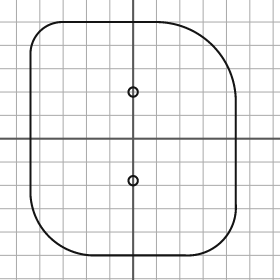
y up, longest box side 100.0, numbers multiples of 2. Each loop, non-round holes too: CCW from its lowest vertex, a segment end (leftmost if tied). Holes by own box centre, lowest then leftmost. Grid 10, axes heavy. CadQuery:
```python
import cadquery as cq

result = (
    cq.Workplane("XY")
    .moveTo(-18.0, -50.0)
    .lineTo(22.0, -50.0)
    .threePointArc((38.0, -44.0), (44.0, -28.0))
    .lineTo(44.0, 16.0)
    .threePointArc((34.0, 40.0), (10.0, 50.0))
    .lineTo(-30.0, 50.0)
    .threePointArc((-40.0, 46.0), (-44.0, 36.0))
    .lineTo(-44.0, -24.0)
    .threePointArc((-36.0, -42.0), (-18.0, -50.0))
    .close()
    .moveTo(0.0, -18.0)
    .circle(2.0)
    .moveTo(0.0, 20.0)
    .circle(2.0)
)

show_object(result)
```